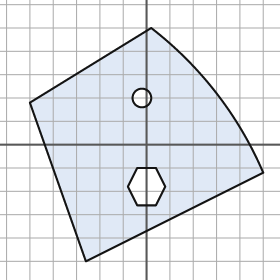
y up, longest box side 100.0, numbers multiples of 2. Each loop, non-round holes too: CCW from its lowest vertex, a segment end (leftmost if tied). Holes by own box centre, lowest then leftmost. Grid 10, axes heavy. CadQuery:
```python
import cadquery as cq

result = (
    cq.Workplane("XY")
    .moveTo(-26.0, -50.0)
    .lineTo(50.0, -12.0)
    .threePointArc((30.0, 22.0), (2.0, 50.0))
    .lineTo(-50.0, 18.0)
    .close()
    .moveTo(-4.0, -26.0)
    .lineTo(4.0, -26.0)
    .lineTo(8.0, -18.0)
    .lineTo(4.0, -10.0)
    .lineTo(-4.0, -10.0)
    .lineTo(-8.0, -18.0)
    .close()
    .moveTo(-2.0, 20.0)
    .circle(4.0)
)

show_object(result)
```